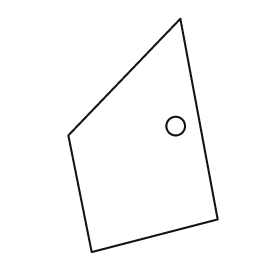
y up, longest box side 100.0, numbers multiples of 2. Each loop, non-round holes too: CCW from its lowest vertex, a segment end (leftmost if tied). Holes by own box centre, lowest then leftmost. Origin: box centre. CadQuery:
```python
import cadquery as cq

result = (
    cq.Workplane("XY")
    .moveTo(-22.0, -50.0)
    .lineTo(32.0, -36.0)
    .lineTo(16.0, 50.0)
    .lineTo(-32.0, 0.0)
    .close()
    .moveTo(14.0, 4.0)
    .circle(4.0)
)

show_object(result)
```